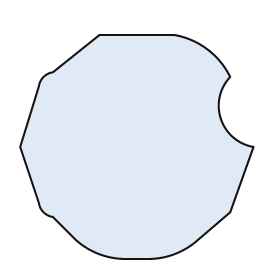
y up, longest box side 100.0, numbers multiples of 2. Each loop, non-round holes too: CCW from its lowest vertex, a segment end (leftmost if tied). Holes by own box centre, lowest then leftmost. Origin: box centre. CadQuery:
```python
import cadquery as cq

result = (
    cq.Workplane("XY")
    .moveTo(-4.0, -48.0)
    .lineTo(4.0, -48.0)
    .threePointArc((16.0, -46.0), (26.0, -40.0))
    .lineTo(40.0, -28.0)
    .lineTo(50.0, 0.0)
    .threePointArc((36.0, 12.0), (40.0, 30.0))
    .threePointArc((30.0, 42.0), (16.0, 48.0))
    .lineTo(-16.0, 48.0)
    .lineTo(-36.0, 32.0)
    .threePointArc((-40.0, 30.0), (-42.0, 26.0))
    .lineTo(-50.0, 0.0)
    .lineTo(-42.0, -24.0)
    .threePointArc((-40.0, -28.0), (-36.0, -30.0))
    .lineTo(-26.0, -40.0)
    .threePointArc((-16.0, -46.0), (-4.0, -48.0))
    .close()
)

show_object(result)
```